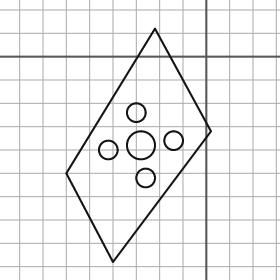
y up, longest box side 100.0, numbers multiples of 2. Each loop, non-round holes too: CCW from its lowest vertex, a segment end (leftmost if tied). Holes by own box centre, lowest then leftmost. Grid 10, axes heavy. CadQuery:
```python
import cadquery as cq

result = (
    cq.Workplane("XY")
    .moveTo(-40.0, -88.0)
    .lineTo(2.0, -32.0)
    .lineTo(-22.0, 12.0)
    .lineTo(-60.0, -50.0)
    .close()
    .moveTo(-26.0, -52.0)
    .circle(4.0)
    .moveTo(-42.0, -40.0)
    .circle(4.0)
    .moveTo(-28.0, -38.0)
    .circle(6.0)
    .moveTo(-14.0, -36.0)
    .circle(4.0)
    .moveTo(-30.0, -24.0)
    .circle(4.0)
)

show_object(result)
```